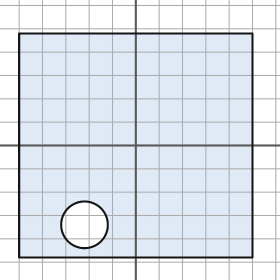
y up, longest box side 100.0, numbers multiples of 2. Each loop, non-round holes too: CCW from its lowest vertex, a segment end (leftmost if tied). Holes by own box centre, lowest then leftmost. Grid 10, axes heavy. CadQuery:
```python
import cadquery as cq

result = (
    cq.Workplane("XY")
    .moveTo(-50.0, -48.0)
    .lineTo(50.0, -48.0)
    .lineTo(50.0, 48.0)
    .lineTo(-50.0, 48.0)
    .close()
    .moveTo(-22.0, -34.0)
    .circle(10.0)
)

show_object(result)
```